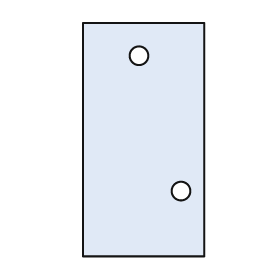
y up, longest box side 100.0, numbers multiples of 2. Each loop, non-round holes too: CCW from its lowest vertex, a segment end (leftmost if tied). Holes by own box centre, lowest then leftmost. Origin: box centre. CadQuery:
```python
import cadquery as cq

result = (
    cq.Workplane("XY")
    .moveTo(-26.0, -50.0)
    .lineTo(26.0, -50.0)
    .lineTo(26.0, 50.0)
    .lineTo(-26.0, 50.0)
    .close()
    .moveTo(16.0, -22.0)
    .circle(4.0)
    .moveTo(-2.0, 36.0)
    .circle(4.0)
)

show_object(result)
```